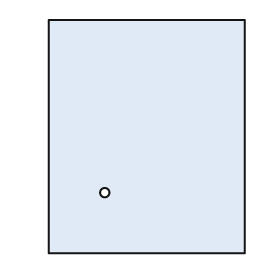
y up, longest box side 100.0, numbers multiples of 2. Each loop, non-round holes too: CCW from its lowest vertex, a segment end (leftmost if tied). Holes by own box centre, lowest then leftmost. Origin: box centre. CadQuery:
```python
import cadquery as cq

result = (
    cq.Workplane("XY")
    .moveTo(-42.0, -50.0)
    .lineTo(42.0, -50.0)
    .lineTo(42.0, 50.0)
    .lineTo(-42.0, 50.0)
    .close()
    .moveTo(-18.0, -24.0)
    .circle(2.0)
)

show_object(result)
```